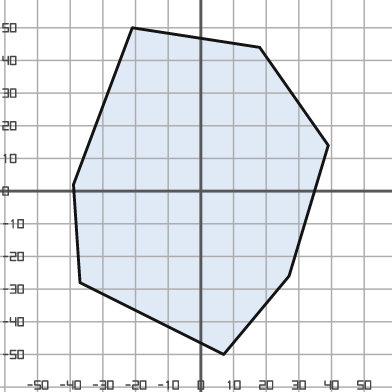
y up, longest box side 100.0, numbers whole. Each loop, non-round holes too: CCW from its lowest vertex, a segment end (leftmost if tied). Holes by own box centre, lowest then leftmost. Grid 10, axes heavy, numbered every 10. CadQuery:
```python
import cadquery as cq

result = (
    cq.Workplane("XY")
    .moveTo(7.0, -50.0)
    .lineTo(27.0, -26.0)
    .lineTo(39.0, 14.0)
    .lineTo(18.0, 44.0)
    .lineTo(-21.0, 50.0)
    .lineTo(-39.0, 2.0)
    .lineTo(-37.0, -28.0)
    .close()
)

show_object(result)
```